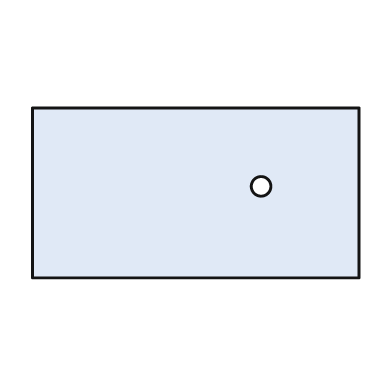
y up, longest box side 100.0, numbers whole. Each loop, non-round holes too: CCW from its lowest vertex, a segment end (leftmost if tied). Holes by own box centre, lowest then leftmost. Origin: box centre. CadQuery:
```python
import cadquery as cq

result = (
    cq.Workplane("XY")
    .moveTo(-50.0, -26.0)
    .lineTo(50.0, -26.0)
    .lineTo(50.0, 26.0)
    .lineTo(-50.0, 26.0)
    .close()
    .moveTo(20.0, 2.0)
    .circle(3.0)
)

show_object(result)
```